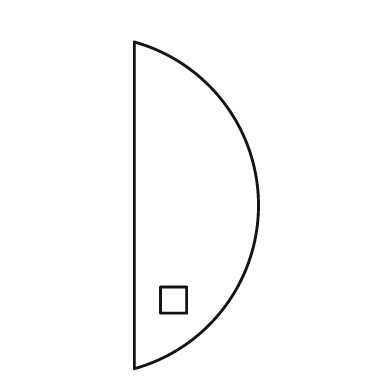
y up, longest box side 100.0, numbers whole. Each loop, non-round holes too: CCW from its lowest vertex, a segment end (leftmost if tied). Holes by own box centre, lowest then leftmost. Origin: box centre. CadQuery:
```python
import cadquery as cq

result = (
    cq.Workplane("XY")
    .moveTo(-19.0, -50.0)
    .threePointArc((19.0, 0.0), (-19.0, 50.0))
    .close()
    .moveTo(-11.0, -33.0)
    .lineTo(-3.0, -33.0)
    .lineTo(-3.0, -25.0)
    .lineTo(-11.0, -25.0)
    .close()
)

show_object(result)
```